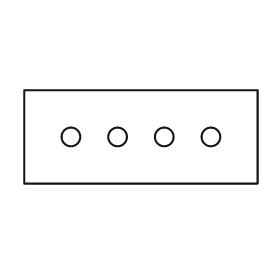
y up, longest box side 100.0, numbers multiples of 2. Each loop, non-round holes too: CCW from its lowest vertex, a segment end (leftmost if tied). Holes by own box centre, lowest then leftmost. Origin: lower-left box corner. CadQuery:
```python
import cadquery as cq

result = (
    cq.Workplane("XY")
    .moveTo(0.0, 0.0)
    .lineTo(100.0, 0.0)
    .lineTo(100.0, 40.0)
    .lineTo(0.0, 40.0)
    .close()
    .moveTo(20.0, 20.0)
    .circle(4.0)
    .moveTo(40.0, 20.0)
    .circle(4.0)
    .moveTo(60.0, 20.0)
    .circle(4.0)
    .moveTo(80.0, 20.0)
    .circle(4.0)
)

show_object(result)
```